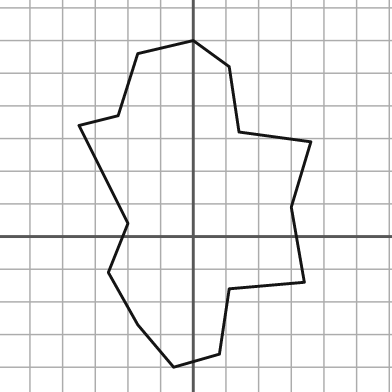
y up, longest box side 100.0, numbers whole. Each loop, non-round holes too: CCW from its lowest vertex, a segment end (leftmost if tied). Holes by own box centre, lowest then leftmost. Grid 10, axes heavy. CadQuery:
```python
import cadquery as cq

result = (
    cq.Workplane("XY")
    .moveTo(-6.0, -40.0)
    .lineTo(8.0, -36.0)
    .lineTo(11.0, -16.0)
    .lineTo(34.0, -14.0)
    .lineTo(30.0, 9.0)
    .lineTo(36.0, 29.0)
    .lineTo(14.0, 32.0)
    .lineTo(11.0, 52.0)
    .lineTo(0.0, 60.0)
    .lineTo(-17.0, 56.0)
    .lineTo(-23.0, 37.0)
    .lineTo(-35.0, 34.0)
    .lineTo(-20.0, 4.0)
    .lineTo(-26.0, -11.0)
    .lineTo(-17.0, -27.0)
    .close()
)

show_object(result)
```